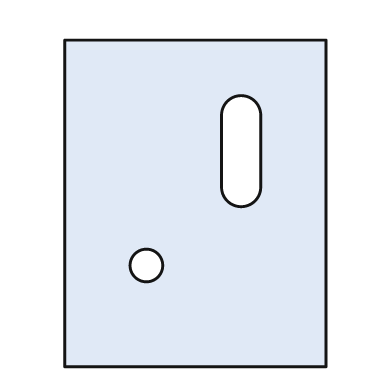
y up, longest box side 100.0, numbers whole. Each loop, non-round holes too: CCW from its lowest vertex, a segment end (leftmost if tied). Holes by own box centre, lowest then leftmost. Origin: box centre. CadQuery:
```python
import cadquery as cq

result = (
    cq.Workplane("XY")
    .moveTo(-40.0, -50.0)
    .lineTo(40.0, -50.0)
    .lineTo(40.0, 50.0)
    .lineTo(-40.0, 50.0)
    .close()
    .moveTo(-15.0, -19.0)
    .circle(5.0)
    .moveTo(8.0, 5.0)
    .threePointArc((14.0, -1.0), (20.0, 5.0))
    .lineTo(20.0, 27.0)
    .threePointArc((14.0, 33.0), (8.0, 27.0))
    .close()
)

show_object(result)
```